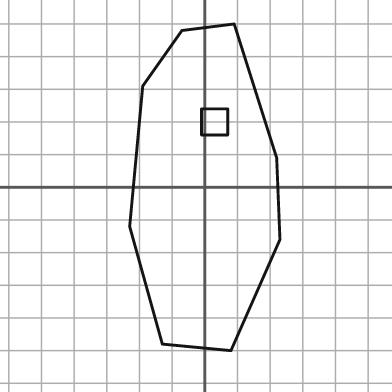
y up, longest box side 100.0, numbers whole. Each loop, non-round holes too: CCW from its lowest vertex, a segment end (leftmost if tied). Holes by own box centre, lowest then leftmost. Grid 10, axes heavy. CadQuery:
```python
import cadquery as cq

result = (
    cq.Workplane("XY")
    .moveTo(8.0, -50.0)
    .lineTo(23.0, -16.0)
    .lineTo(22.0, 9.0)
    .lineTo(9.0, 50.0)
    .lineTo(-7.0, 48.0)
    .lineTo(-19.0, 31.0)
    .lineTo(-23.0, -12.0)
    .lineTo(-13.0, -48.0)
    .close()
    .moveTo(-1.0, 16.0)
    .lineTo(7.0, 16.0)
    .lineTo(7.0, 24.0)
    .lineTo(-1.0, 24.0)
    .close()
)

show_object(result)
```